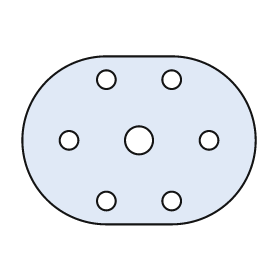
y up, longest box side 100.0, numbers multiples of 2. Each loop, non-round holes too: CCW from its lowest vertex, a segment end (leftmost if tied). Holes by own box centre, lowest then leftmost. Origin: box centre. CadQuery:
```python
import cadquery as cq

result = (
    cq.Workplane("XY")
    .moveTo(-14.0, -36.0)
    .lineTo(14.0, -36.0)
    .threePointArc((50.0, 0.0), (14.0, 36.0))
    .lineTo(-14.0, 36.0)
    .threePointArc((-50.0, 0.0), (-14.0, -36.0))
    .close()
    .moveTo(-14.0, -26.0)
    .circle(4.0)
    .moveTo(14.0, -26.0)
    .circle(4.0)
    .moveTo(-30.0, 0.0)
    .circle(4.0)
    .moveTo(0.0, 0.0)
    .circle(6.0)
    .moveTo(30.0, 0.0)
    .circle(4.0)
    .moveTo(-14.0, 26.0)
    .circle(4.0)
    .moveTo(14.0, 26.0)
    .circle(4.0)
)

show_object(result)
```